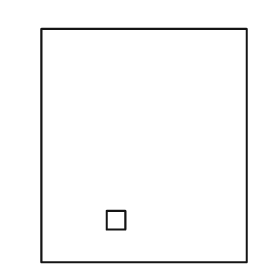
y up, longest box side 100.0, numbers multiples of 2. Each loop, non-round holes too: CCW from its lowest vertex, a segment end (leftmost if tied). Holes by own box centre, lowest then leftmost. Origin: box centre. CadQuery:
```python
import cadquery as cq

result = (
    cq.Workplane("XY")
    .moveTo(-44.0, -50.0)
    .lineTo(44.0, -50.0)
    .lineTo(44.0, 50.0)
    .lineTo(-44.0, 50.0)
    .close()
    .moveTo(-16.0, -36.0)
    .lineTo(-8.0, -36.0)
    .lineTo(-8.0, -28.0)
    .lineTo(-16.0, -28.0)
    .close()
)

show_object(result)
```